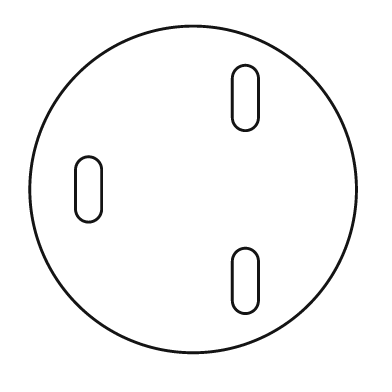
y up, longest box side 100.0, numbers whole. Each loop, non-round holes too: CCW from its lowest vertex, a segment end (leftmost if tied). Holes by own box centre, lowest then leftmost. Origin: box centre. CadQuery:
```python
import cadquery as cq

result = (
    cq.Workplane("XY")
    .moveTo(0.0, 0.0)
    .circle(50.0)
    .moveTo(12.0, -34.0)
    .threePointArc((16.0, -38.0), (20.0, -34.0))
    .lineTo(20.0, -22.0)
    .threePointArc((16.0, -18.0), (12.0, -22.0))
    .close()
    .moveTo(-36.0, -6.0)
    .threePointArc((-32.0, -10.0), (-28.0, -6.0))
    .lineTo(-28.0, 6.0)
    .threePointArc((-32.0, 10.0), (-36.0, 6.0))
    .close()
    .moveTo(12.0, 22.0)
    .threePointArc((16.0, 18.0), (20.0, 22.0))
    .lineTo(20.0, 34.0)
    .threePointArc((16.0, 38.0), (12.0, 34.0))
    .close()
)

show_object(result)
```